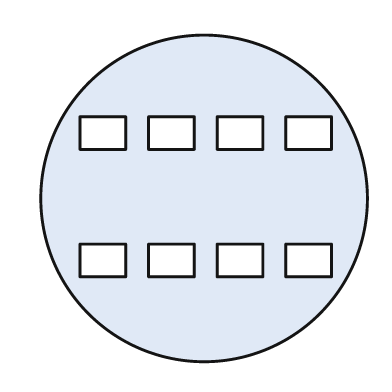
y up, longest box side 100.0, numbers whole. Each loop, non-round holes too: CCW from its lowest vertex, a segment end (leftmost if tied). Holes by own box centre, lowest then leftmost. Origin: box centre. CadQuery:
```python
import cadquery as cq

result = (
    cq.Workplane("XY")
    .moveTo(0.0, 0.0)
    .circle(50.0)
    .moveTo(-38.0, -24.0)
    .lineTo(-24.0, -24.0)
    .lineTo(-24.0, -14.0)
    .lineTo(-38.0, -14.0)
    .close()
    .moveTo(-17.0, -24.0)
    .lineTo(-3.0, -24.0)
    .lineTo(-3.0, -14.0)
    .lineTo(-17.0, -14.0)
    .close()
    .moveTo(4.0, -24.0)
    .lineTo(18.0, -24.0)
    .lineTo(18.0, -14.0)
    .lineTo(4.0, -14.0)
    .close()
    .moveTo(25.0, -24.0)
    .lineTo(39.0, -24.0)
    .lineTo(39.0, -14.0)
    .lineTo(25.0, -14.0)
    .close()
    .moveTo(-38.0, 15.0)
    .lineTo(-24.0, 15.0)
    .lineTo(-24.0, 25.0)
    .lineTo(-38.0, 25.0)
    .close()
    .moveTo(-17.0, 15.0)
    .lineTo(-3.0, 15.0)
    .lineTo(-3.0, 25.0)
    .lineTo(-17.0, 25.0)
    .close()
    .moveTo(4.0, 15.0)
    .lineTo(18.0, 15.0)
    .lineTo(18.0, 25.0)
    .lineTo(4.0, 25.0)
    .close()
    .moveTo(25.0, 15.0)
    .lineTo(39.0, 15.0)
    .lineTo(39.0, 25.0)
    .lineTo(25.0, 25.0)
    .close()
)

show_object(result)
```